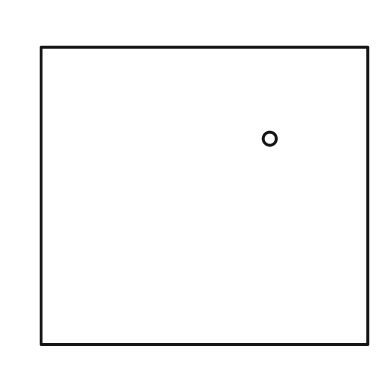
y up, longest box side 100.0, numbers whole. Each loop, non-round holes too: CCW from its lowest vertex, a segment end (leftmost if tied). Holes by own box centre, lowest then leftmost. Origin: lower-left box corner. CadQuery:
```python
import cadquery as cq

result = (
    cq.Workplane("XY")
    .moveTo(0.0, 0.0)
    .lineTo(100.0, 0.0)
    .lineTo(100.0, 91.0)
    .lineTo(0.0, 91.0)
    .close()
    .moveTo(70.0, 63.0)
    .circle(2.0)
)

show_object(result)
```